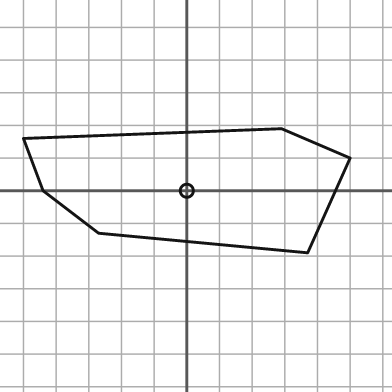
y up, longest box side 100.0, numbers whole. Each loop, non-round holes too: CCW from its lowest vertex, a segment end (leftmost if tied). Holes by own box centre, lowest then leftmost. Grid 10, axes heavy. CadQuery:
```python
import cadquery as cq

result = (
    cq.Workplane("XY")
    .moveTo(37.0, -19.0)
    .lineTo(50.0, 10.0)
    .lineTo(29.0, 19.0)
    .lineTo(-50.0, 16.0)
    .lineTo(-44.0, 0.0)
    .lineTo(-27.0, -13.0)
    .close()
    .moveTo(0.0, 0.0)
    .circle(2.0)
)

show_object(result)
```